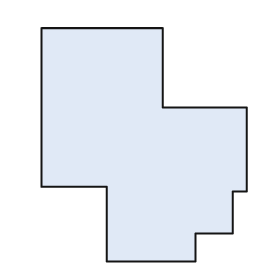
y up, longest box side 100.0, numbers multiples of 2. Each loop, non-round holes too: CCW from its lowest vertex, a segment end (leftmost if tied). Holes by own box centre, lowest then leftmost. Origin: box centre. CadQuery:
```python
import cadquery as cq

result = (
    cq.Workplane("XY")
    .moveTo(-16.0, -50.0)
    .lineTo(22.0, -50.0)
    .lineTo(22.0, -38.0)
    .lineTo(38.0, -38.0)
    .lineTo(38.0, -20.0)
    .lineTo(44.0, -20.0)
    .lineTo(44.0, 16.0)
    .lineTo(8.0, 16.0)
    .lineTo(8.0, 50.0)
    .lineTo(-44.0, 50.0)
    .lineTo(-44.0, -18.0)
    .lineTo(-16.0, -18.0)
    .close()
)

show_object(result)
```